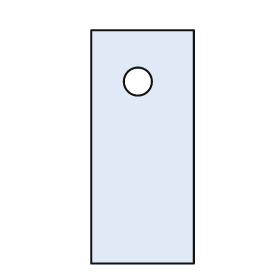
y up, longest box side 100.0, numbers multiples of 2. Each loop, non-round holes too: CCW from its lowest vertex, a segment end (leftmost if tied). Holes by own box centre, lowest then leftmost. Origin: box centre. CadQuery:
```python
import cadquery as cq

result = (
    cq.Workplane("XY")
    .moveTo(-22.0, -50.0)
    .lineTo(22.0, -50.0)
    .lineTo(22.0, 50.0)
    .lineTo(-22.0, 50.0)
    .close()
    .moveTo(-2.0, 28.0)
    .circle(6.0)
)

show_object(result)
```